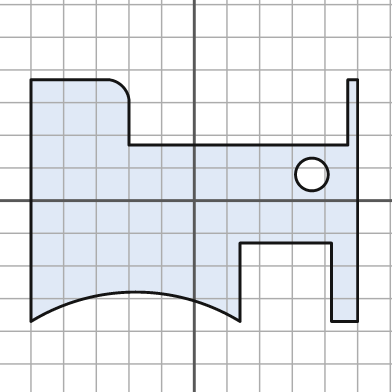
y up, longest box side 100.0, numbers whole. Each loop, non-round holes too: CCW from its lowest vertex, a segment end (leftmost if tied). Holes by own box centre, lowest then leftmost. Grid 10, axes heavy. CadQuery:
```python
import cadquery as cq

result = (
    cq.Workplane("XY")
    .moveTo(-50.0, -37.0)
    .threePointArc((-18.0, -28.0), (14.0, -37.0))
    .lineTo(14.0, -13.0)
    .lineTo(42.0, -13.0)
    .lineTo(42.0, -37.0)
    .lineTo(50.0, -37.0)
    .lineTo(50.0, 37.0)
    .lineTo(47.0, 37.0)
    .lineTo(47.0, 17.0)
    .lineTo(-20.0, 17.0)
    .lineTo(-20.0, 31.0)
    .threePointArc((-22.0, 35.0), (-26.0, 37.0))
    .lineTo(-50.0, 37.0)
    .close()
    .moveTo(36.0, 8.0)
    .circle(5.0)
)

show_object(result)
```